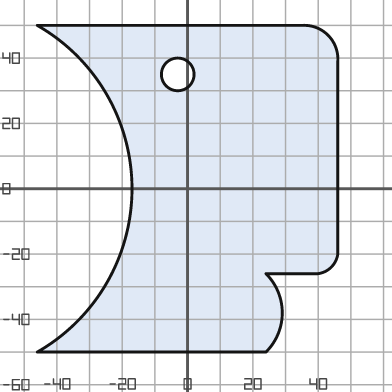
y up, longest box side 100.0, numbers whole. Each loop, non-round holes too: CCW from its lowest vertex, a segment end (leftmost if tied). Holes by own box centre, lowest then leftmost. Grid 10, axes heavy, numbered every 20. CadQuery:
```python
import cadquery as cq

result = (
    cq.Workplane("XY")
    .moveTo(-46.0, -50.0)
    .lineTo(24.0, -50.0)
    .threePointArc((29.0, -38.0), (24.0, -26.0))
    .lineTo(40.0, -26.0)
    .threePointArc((44.0, -24.0), (46.0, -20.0))
    .lineTo(46.0, 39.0)
    .threePointArc((43.0, 47.0), (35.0, 50.0))
    .lineTo(-46.0, 50.0)
    .threePointArc((-17.0, 0.0), (-46.0, -50.0))
    .close()
    .moveTo(-3.0, 35.0)
    .circle(5.0)
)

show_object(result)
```